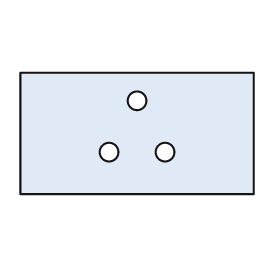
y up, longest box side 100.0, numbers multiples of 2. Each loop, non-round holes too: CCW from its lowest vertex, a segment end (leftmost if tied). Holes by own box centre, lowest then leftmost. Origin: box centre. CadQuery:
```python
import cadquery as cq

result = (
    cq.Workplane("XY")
    .moveTo(-50.0, -26.0)
    .lineTo(50.0, -26.0)
    .lineTo(50.0, 26.0)
    .lineTo(-50.0, 26.0)
    .close()
    .moveTo(-12.0, -8.0)
    .circle(4.0)
    .moveTo(12.0, -8.0)
    .circle(4.0)
    .moveTo(0.0, 14.0)
    .circle(4.0)
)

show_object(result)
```